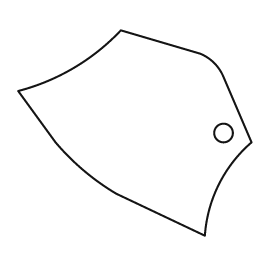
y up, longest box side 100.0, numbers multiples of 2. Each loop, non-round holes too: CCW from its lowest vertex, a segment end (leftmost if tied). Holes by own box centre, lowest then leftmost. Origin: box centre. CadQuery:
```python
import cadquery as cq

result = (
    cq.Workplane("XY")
    .moveTo(30.0, -44.0)
    .threePointArc((36.0, -22.0), (50.0, -4.0))
    .lineTo(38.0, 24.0)
    .threePointArc((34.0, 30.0), (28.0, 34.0))
    .lineTo(-6.0, 44.0)
    .threePointArc((-26.0, 28.0), (-50.0, 18.0))
    .lineTo(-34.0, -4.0)
    .threePointArc((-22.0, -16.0), (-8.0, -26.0))
    .close()
    .moveTo(38.0, 0.0)
    .circle(4.0)
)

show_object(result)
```